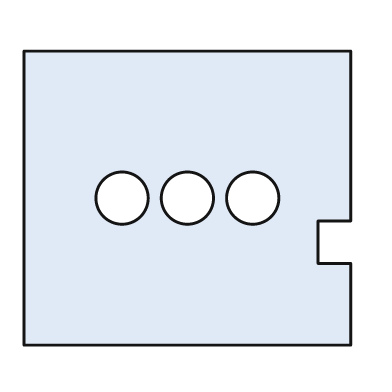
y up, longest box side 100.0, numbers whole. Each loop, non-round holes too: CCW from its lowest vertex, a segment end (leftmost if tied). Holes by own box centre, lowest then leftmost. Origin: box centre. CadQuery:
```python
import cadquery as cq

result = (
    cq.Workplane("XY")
    .moveTo(-50.0, -45.0)
    .lineTo(50.0, -45.0)
    .lineTo(50.0, -20.0)
    .lineTo(40.0, -20.0)
    .lineTo(40.0, -7.0)
    .lineTo(50.0, -7.0)
    .lineTo(50.0, 45.0)
    .lineTo(-50.0, 45.0)
    .close()
    .moveTo(-20.0, 0.0)
    .circle(8.0)
    .moveTo(0.0, 0.0)
    .circle(8.0)
    .moveTo(20.0, 0.0)
    .circle(8.0)
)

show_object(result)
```